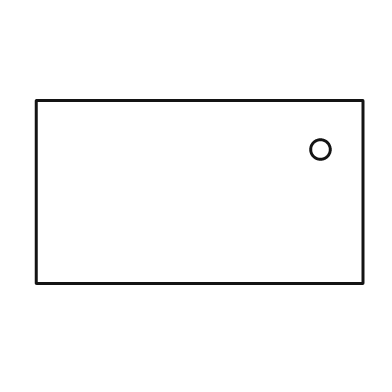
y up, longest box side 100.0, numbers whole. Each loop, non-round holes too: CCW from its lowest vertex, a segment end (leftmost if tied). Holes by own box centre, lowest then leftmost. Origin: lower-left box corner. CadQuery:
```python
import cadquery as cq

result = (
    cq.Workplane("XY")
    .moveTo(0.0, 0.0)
    .lineTo(100.0, 0.0)
    .lineTo(100.0, 56.0)
    .lineTo(0.0, 56.0)
    .close()
    .moveTo(87.0, 41.0)
    .circle(3.0)
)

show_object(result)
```